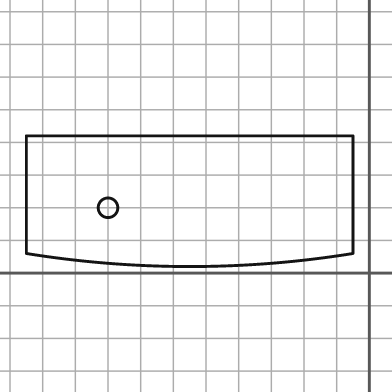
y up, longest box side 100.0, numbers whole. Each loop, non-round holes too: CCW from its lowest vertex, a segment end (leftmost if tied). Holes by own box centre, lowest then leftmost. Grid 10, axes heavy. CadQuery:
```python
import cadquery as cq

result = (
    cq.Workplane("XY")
    .moveTo(-105.0, 6.0)
    .threePointArc((-55.0, 2.0), (-5.0, 6.0))
    .lineTo(-5.0, 42.0)
    .lineTo(-105.0, 42.0)
    .close()
    .moveTo(-80.0, 20.0)
    .circle(3.0)
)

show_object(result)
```